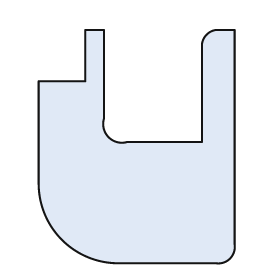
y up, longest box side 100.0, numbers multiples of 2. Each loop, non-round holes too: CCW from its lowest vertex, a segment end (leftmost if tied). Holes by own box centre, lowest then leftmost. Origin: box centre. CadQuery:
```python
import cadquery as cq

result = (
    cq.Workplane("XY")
    .moveTo(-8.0, -50.0)
    .lineTo(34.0, -50.0)
    .threePointArc((40.0, -48.0), (42.0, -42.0))
    .lineTo(42.0, 50.0)
    .lineTo(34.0, 50.0)
    .threePointArc((30.0, 48.0), (28.0, 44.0))
    .lineTo(28.0, 2.0)
    .lineTo(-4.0, 2.0)
    .threePointArc((-12.0, 4.0), (-14.0, 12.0))
    .lineTo(-14.0, 50.0)
    .lineTo(-22.0, 50.0)
    .lineTo(-22.0, 28.0)
    .lineTo(-42.0, 28.0)
    .lineTo(-42.0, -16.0)
    .threePointArc((-32.0, -40.0), (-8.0, -50.0))
    .close()
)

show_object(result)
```